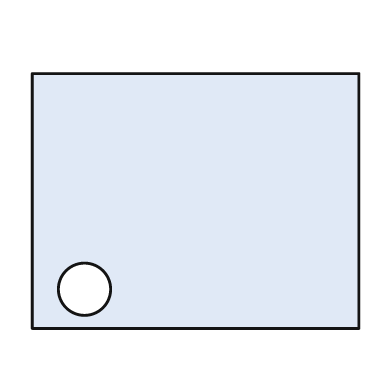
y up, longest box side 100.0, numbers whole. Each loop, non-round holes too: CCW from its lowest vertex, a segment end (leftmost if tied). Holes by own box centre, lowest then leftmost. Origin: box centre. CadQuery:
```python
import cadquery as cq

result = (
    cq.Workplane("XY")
    .moveTo(-50.0, -39.0)
    .lineTo(50.0, -39.0)
    .lineTo(50.0, 39.0)
    .lineTo(-50.0, 39.0)
    .close()
    .moveTo(-34.0, -27.0)
    .circle(8.0)
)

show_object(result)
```